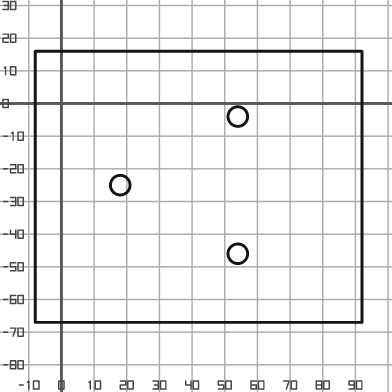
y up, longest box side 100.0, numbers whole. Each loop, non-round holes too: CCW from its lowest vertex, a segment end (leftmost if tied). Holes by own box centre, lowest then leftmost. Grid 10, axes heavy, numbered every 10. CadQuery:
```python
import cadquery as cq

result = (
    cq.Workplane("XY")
    .moveTo(-8.0, -67.0)
    .lineTo(92.0, -67.0)
    .lineTo(92.0, 16.0)
    .lineTo(-8.0, 16.0)
    .close()
    .moveTo(54.0, -46.0)
    .circle(3.0)
    .moveTo(18.0, -25.0)
    .circle(3.0)
    .moveTo(54.0, -4.0)
    .circle(3.0)
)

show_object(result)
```